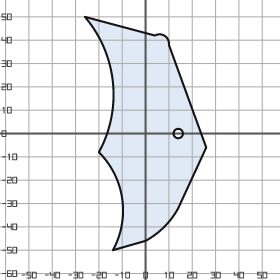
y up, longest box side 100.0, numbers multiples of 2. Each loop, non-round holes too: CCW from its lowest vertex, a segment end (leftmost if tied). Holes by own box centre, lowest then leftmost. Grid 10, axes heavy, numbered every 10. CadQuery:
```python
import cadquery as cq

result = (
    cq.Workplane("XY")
    .moveTo(-14.0, -50.0)
    .lineTo(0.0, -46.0)
    .threePointArc((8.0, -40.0), (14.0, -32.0))
    .lineTo(26.0, -6.0)
    .lineTo(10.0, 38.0)
    .threePointArc((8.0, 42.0), (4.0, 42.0))
    .lineTo(-26.0, 50.0)
    .threePointArc((-14.0, 22.0), (-20.0, -8.0))
    .threePointArc((-10.0, -28.0), (-14.0, -50.0))
    .close()
    .moveTo(14.0, 0.0)
    .circle(2.0)
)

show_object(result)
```